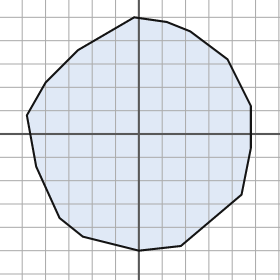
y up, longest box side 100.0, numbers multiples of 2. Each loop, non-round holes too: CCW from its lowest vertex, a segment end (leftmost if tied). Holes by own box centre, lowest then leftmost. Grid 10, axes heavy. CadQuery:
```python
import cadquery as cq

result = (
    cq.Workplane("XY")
    .moveTo(0.0, -50.0)
    .lineTo(18.0, -48.0)
    .lineTo(44.0, -26.0)
    .lineTo(48.0, -6.0)
    .lineTo(48.0, 12.0)
    .lineTo(38.0, 32.0)
    .lineTo(22.0, 44.0)
    .lineTo(12.0, 48.0)
    .lineTo(-2.0, 50.0)
    .lineTo(-26.0, 36.0)
    .lineTo(-40.0, 22.0)
    .lineTo(-48.0, 8.0)
    .lineTo(-44.0, -14.0)
    .lineTo(-34.0, -36.0)
    .lineTo(-24.0, -44.0)
    .close()
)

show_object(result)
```